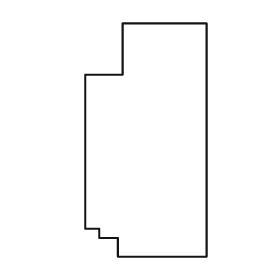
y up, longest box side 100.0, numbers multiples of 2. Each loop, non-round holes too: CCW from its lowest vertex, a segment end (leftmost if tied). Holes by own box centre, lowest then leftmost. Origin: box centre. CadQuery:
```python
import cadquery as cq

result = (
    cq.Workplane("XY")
    .moveTo(-12.0, -50.0)
    .lineTo(26.0, -50.0)
    .lineTo(26.0, 50.0)
    .lineTo(-10.0, 50.0)
    .lineTo(-10.0, 28.0)
    .lineTo(-26.0, 28.0)
    .lineTo(-26.0, -38.0)
    .lineTo(-20.0, -38.0)
    .lineTo(-20.0, -42.0)
    .lineTo(-12.0, -42.0)
    .close()
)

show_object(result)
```